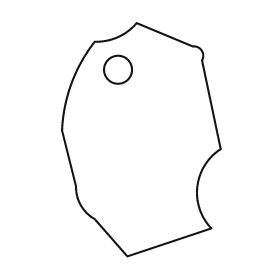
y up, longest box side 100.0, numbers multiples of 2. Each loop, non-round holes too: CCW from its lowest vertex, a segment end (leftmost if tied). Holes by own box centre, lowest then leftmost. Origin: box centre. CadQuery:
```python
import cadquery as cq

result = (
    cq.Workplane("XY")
    .moveTo(-6.0, -50.0)
    .lineTo(30.0, -38.0)
    .threePointArc((24.0, -20.0), (34.0, -4.0))
    .lineTo(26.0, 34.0)
    .threePointArc((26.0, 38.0), (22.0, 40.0))
    .lineTo(-2.0, 50.0)
    .threePointArc((-10.0, 44.0), (-20.0, 42.0))
    .threePointArc((-30.0, 24.0), (-34.0, 4.0))
    .lineTo(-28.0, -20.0)
    .threePointArc((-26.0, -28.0), (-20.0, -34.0))
    .close()
    .moveTo(-10.0, 30.0)
    .circle(6.0)
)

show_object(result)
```